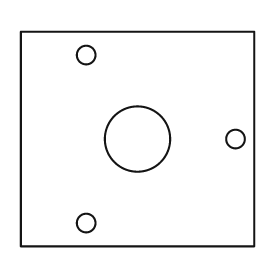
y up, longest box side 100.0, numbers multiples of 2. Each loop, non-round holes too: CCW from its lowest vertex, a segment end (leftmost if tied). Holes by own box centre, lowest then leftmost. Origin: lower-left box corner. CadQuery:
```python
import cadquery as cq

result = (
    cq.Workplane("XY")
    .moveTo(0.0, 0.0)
    .lineTo(100.0, 0.0)
    .lineTo(100.0, 92.0)
    .lineTo(0.0, 92.0)
    .close()
    .moveTo(28.0, 10.0)
    .circle(4.0)
    .moveTo(50.0, 46.0)
    .circle(14.0)
    .moveTo(92.0, 46.0)
    .circle(4.0)
    .moveTo(28.0, 82.0)
    .circle(4.0)
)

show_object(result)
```